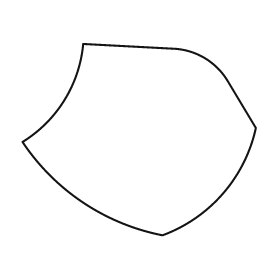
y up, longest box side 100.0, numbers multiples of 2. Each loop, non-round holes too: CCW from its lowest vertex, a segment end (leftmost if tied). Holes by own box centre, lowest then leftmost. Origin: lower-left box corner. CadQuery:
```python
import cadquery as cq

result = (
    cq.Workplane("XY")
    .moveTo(60.0, 0.0)
    .threePointArc((86.0, 18.0), (100.0, 46.0))
    .lineTo(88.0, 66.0)
    .threePointArc((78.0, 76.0), (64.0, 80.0))
    .lineTo(26.0, 82.0)
    .threePointArc((18.0, 58.0), (0.0, 40.0))
    .threePointArc((26.0, 14.0), (60.0, 0.0))
    .close()
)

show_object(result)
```